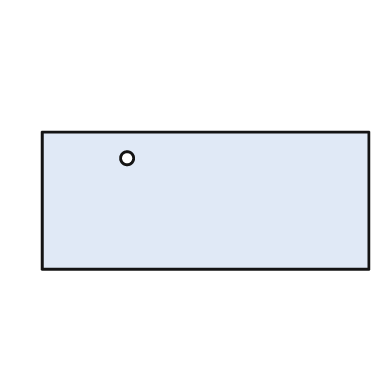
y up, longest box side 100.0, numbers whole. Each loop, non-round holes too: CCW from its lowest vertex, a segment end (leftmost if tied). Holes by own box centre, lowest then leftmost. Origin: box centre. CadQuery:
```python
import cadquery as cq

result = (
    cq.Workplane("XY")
    .moveTo(-50.0, -21.0)
    .lineTo(50.0, -21.0)
    .lineTo(50.0, 21.0)
    .lineTo(-50.0, 21.0)
    .close()
    .moveTo(-24.0, 13.0)
    .circle(2.0)
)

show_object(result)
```